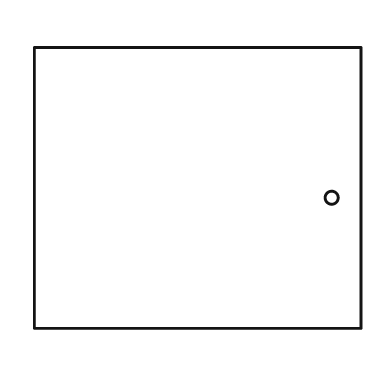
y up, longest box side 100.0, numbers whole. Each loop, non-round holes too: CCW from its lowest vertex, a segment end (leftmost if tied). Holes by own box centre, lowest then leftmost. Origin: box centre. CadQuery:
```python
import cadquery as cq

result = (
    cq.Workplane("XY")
    .moveTo(-50.0, -43.0)
    .lineTo(50.0, -43.0)
    .lineTo(50.0, 43.0)
    .lineTo(-50.0, 43.0)
    .close()
    .moveTo(41.0, -3.0)
    .circle(2.0)
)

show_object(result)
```